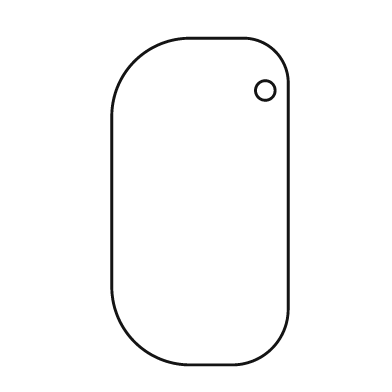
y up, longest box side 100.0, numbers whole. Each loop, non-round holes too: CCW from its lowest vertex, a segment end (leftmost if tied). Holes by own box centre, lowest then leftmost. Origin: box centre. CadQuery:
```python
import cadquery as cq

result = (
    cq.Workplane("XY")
    .moveTo(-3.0, -50.0)
    .lineTo(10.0, -50.0)
    .threePointArc((22.0, -45.0), (27.0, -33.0))
    .lineTo(27.0, 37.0)
    .threePointArc((23.0, 46.0), (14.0, 50.0))
    .lineTo(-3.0, 50.0)
    .threePointArc((-20.0, 43.0), (-27.0, 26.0))
    .lineTo(-27.0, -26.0)
    .threePointArc((-20.0, -43.0), (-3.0, -50.0))
    .close()
    .moveTo(20.0, 34.0)
    .circle(3.0)
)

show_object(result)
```